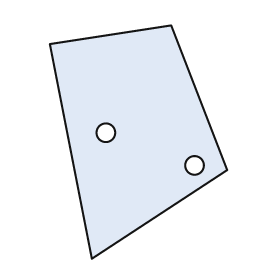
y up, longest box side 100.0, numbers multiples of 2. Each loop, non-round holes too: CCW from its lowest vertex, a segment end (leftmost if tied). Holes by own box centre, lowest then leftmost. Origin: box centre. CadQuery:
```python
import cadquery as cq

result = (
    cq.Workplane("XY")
    .moveTo(-20.0, -50.0)
    .lineTo(38.0, -12.0)
    .lineTo(14.0, 50.0)
    .lineTo(-38.0, 42.0)
    .close()
    .moveTo(24.0, -10.0)
    .circle(4.0)
    .moveTo(-14.0, 4.0)
    .circle(4.0)
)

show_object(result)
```